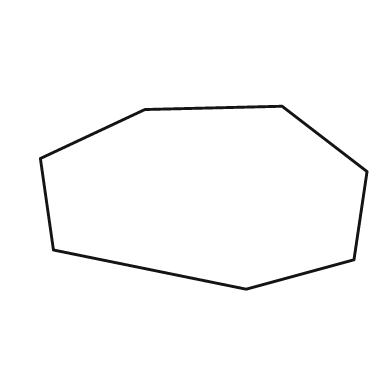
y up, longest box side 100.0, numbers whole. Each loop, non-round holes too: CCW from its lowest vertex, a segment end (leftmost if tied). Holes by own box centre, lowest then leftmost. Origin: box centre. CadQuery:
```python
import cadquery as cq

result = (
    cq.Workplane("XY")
    .moveTo(13.0, -28.0)
    .lineTo(46.0, -19.0)
    .lineTo(50.0, 8.0)
    .lineTo(24.0, 28.0)
    .lineTo(-18.0, 27.0)
    .lineTo(-50.0, 12.0)
    .lineTo(-46.0, -16.0)
    .close()
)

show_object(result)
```